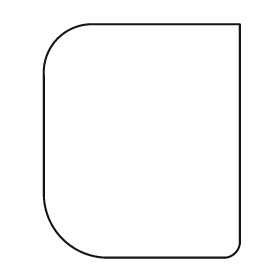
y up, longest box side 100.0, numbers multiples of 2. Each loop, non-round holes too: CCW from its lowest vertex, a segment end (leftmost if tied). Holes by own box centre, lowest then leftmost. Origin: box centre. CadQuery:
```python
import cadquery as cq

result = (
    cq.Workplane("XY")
    .moveTo(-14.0, -50.0)
    .lineTo(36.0, -50.0)
    .threePointArc((40.0, -48.0), (42.0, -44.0))
    .lineTo(42.0, 50.0)
    .lineTo(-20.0, 50.0)
    .threePointArc((-36.0, 44.0), (-42.0, 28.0))
    .lineTo(-42.0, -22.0)
    .threePointArc((-34.0, -42.0), (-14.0, -50.0))
    .close()
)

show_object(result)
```